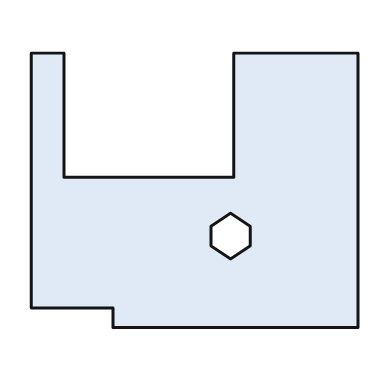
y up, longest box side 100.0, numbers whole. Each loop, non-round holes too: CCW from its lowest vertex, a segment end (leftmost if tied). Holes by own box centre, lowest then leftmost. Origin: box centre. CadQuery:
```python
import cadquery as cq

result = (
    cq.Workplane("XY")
    .moveTo(-25.0, -42.0)
    .lineTo(50.0, -42.0)
    .lineTo(50.0, 42.0)
    .lineTo(12.0, 42.0)
    .lineTo(12.0, 4.0)
    .lineTo(-40.0, 4.0)
    .lineTo(-40.0, 42.0)
    .lineTo(-50.0, 42.0)
    .lineTo(-50.0, -36.0)
    .lineTo(-25.0, -36.0)
    .close()
    .moveTo(11.0, -21.0)
    .lineTo(17.0, -17.0)
    .lineTo(17.0, -11.0)
    .lineTo(11.0, -7.0)
    .lineTo(5.0, -11.0)
    .lineTo(5.0, -17.0)
    .close()
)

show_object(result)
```